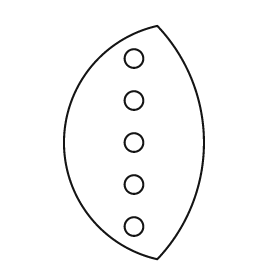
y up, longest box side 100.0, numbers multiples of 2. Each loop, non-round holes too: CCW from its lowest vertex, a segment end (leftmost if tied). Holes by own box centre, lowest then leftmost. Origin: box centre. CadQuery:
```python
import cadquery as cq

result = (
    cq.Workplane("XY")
    .moveTo(10.0, -50.0)
    .threePointArc((30.0, 0.0), (10.0, 50.0))
    .threePointArc((-30.0, 0.0), (10.0, -50.0))
    .close()
    .moveTo(0.0, -36.0)
    .circle(4.0)
    .moveTo(0.0, -18.0)
    .circle(4.0)
    .moveTo(0.0, 0.0)
    .circle(4.0)
    .moveTo(0.0, 18.0)
    .circle(4.0)
    .moveTo(0.0, 36.0)
    .circle(4.0)
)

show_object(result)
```